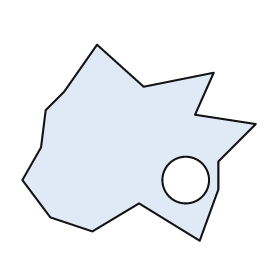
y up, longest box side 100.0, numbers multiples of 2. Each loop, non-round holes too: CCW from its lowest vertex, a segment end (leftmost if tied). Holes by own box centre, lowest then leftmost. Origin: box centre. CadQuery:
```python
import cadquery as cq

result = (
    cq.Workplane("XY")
    .moveTo(26.0, -42.0)
    .lineTo(34.0, -20.0)
    .lineTo(34.0, -8.0)
    .lineTo(50.0, 8.0)
    .lineTo(24.0, 12.0)
    .lineTo(32.0, 30.0)
    .lineTo(2.0, 24.0)
    .lineTo(-18.0, 42.0)
    .lineTo(-32.0, 22.0)
    .lineTo(-40.0, 14.0)
    .lineTo(-42.0, -2.0)
    .lineTo(-50.0, -16.0)
    .lineTo(-38.0, -32.0)
    .lineTo(-20.0, -38.0)
    .lineTo(0.0, -26.0)
    .close()
    .moveTo(20.0, -16.0)
    .circle(10.0)
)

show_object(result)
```